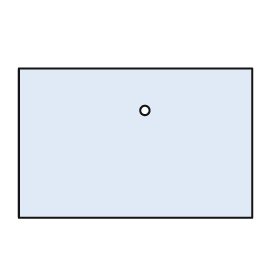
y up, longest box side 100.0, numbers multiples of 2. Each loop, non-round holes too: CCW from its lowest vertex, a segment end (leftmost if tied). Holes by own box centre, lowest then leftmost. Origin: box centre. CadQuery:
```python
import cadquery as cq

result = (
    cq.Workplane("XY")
    .moveTo(-50.0, -32.0)
    .lineTo(50.0, -32.0)
    .lineTo(50.0, 32.0)
    .lineTo(-50.0, 32.0)
    .close()
    .moveTo(4.0, 14.0)
    .circle(2.0)
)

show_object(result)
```